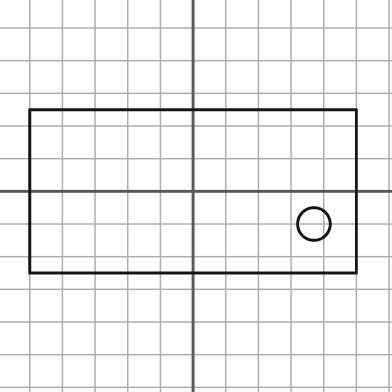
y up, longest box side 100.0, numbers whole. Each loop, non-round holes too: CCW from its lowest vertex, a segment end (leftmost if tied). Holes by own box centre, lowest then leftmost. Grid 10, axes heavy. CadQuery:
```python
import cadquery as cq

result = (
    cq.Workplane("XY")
    .moveTo(-50.0, -25.0)
    .lineTo(50.0, -25.0)
    .lineTo(50.0, 25.0)
    .lineTo(-50.0, 25.0)
    .close()
    .moveTo(37.0, -10.0)
    .circle(5.0)
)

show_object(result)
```